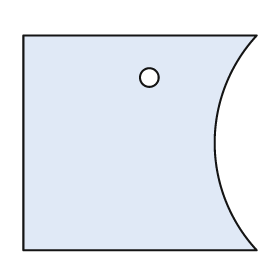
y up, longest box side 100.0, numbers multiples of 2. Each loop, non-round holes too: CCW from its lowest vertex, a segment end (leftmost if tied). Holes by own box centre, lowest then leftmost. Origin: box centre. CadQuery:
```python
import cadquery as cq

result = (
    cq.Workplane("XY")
    .moveTo(-50.0, -46.0)
    .lineTo(50.0, -46.0)
    .threePointArc((32.0, 0.0), (50.0, 46.0))
    .lineTo(-50.0, 46.0)
    .close()
    .moveTo(4.0, 28.0)
    .circle(4.0)
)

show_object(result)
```